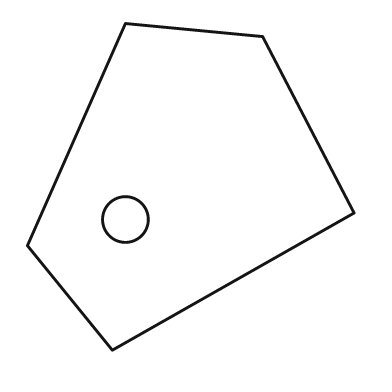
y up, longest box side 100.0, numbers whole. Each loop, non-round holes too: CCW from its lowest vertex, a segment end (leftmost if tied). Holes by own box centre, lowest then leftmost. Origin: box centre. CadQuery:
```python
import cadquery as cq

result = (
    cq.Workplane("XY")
    .moveTo(-24.0, -50.0)
    .lineTo(50.0, -8.0)
    .lineTo(22.0, 46.0)
    .lineTo(-20.0, 50.0)
    .lineTo(-50.0, -18.0)
    .close()
    .moveTo(-20.0, -10.0)
    .circle(7.0)
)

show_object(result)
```